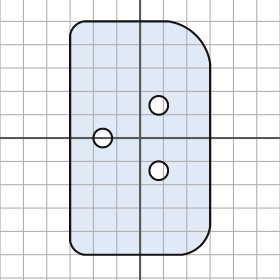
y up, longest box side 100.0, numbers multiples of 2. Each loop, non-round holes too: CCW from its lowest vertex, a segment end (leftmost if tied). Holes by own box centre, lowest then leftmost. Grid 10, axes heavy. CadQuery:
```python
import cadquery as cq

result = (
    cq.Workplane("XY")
    .moveTo(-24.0, -50.0)
    .lineTo(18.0, -50.0)
    .threePointArc((26.0, -46.0), (30.0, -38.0))
    .lineTo(30.0, 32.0)
    .threePointArc((24.0, 44.0), (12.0, 50.0))
    .lineTo(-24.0, 50.0)
    .threePointArc((-28.0, 48.0), (-30.0, 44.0))
    .lineTo(-30.0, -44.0)
    .threePointArc((-28.0, -48.0), (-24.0, -50.0))
    .close()
    .moveTo(8.0, -14.0)
    .circle(4.0)
    .moveTo(-16.0, 0.0)
    .circle(4.0)
    .moveTo(8.0, 14.0)
    .circle(4.0)
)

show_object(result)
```